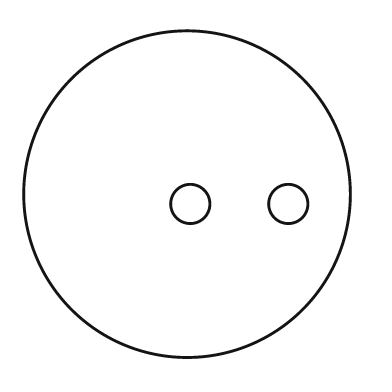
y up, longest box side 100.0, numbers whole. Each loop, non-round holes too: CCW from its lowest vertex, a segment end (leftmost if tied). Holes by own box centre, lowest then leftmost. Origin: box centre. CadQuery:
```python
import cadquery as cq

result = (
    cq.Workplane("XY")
    .moveTo(0.0, 0.0)
    .circle(50.0)
    .moveTo(1.0, -3.0)
    .circle(6.0)
    .moveTo(31.0, -3.0)
    .circle(6.0)
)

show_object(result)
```